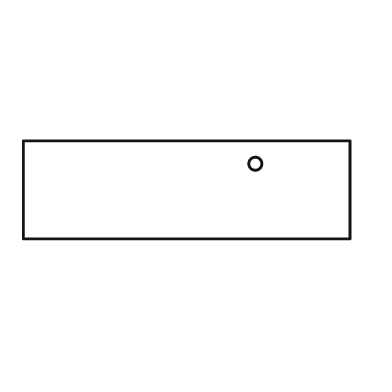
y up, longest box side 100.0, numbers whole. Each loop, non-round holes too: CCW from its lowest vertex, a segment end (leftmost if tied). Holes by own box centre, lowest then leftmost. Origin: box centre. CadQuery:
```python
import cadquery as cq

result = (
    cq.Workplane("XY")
    .moveTo(-50.0, -15.0)
    .lineTo(50.0, -15.0)
    .lineTo(50.0, 15.0)
    .lineTo(-50.0, 15.0)
    .close()
    .moveTo(21.0, 8.0)
    .circle(2.0)
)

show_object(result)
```